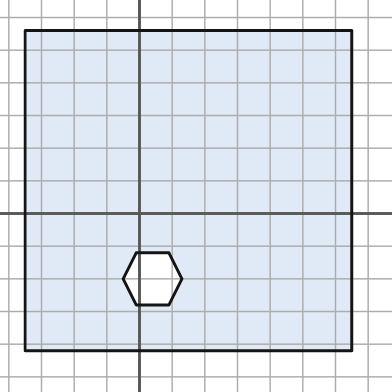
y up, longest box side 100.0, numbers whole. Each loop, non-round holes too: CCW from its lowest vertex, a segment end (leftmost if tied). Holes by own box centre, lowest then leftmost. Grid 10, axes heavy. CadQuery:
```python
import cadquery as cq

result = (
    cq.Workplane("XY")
    .moveTo(-35.0, -42.0)
    .lineTo(65.0, -42.0)
    .lineTo(65.0, 56.0)
    .lineTo(-35.0, 56.0)
    .close()
    .moveTo(-1.0, -28.0)
    .lineTo(9.0, -28.0)
    .lineTo(13.0, -20.0)
    .lineTo(9.0, -12.0)
    .lineTo(-1.0, -12.0)
    .lineTo(-5.0, -20.0)
    .close()
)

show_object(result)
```